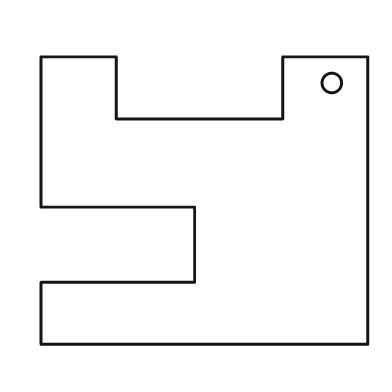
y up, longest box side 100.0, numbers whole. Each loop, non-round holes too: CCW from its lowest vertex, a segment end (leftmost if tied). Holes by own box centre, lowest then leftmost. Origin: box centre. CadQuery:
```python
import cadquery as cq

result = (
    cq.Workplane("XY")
    .moveTo(-50.0, -44.0)
    .lineTo(50.0, -44.0)
    .lineTo(50.0, 44.0)
    .lineTo(24.0, 44.0)
    .lineTo(24.0, 25.0)
    .lineTo(-27.0, 25.0)
    .lineTo(-27.0, 44.0)
    .lineTo(-50.0, 44.0)
    .lineTo(-50.0, -2.0)
    .lineTo(-3.0, -2.0)
    .lineTo(-3.0, -25.0)
    .lineTo(-50.0, -25.0)
    .close()
    .moveTo(39.0, 36.0)
    .circle(3.0)
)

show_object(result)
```